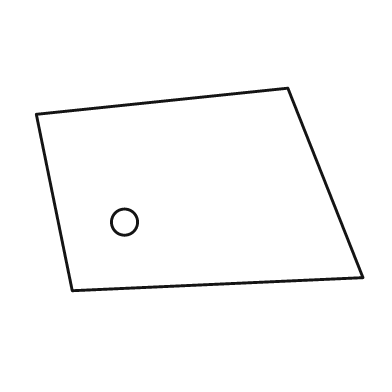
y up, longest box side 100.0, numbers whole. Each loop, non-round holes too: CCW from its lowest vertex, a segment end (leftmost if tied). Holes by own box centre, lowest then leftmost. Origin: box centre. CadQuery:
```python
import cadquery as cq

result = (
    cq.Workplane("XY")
    .moveTo(-39.0, -31.0)
    .lineTo(50.0, -27.0)
    .lineTo(27.0, 31.0)
    .lineTo(-50.0, 23.0)
    .close()
    .moveTo(-23.0, -10.0)
    .circle(4.0)
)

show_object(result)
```